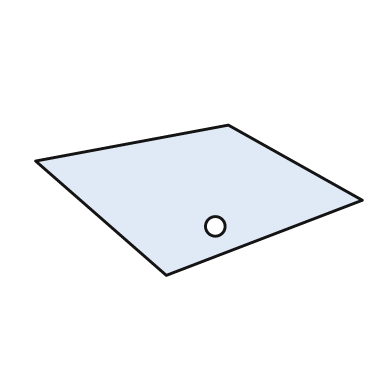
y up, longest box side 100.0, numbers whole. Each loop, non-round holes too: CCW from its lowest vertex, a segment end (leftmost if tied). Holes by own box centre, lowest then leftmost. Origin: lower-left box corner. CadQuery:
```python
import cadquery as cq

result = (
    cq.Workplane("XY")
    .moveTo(40.0, 0.0)
    .lineTo(100.0, 23.0)
    .lineTo(59.0, 46.0)
    .lineTo(0.0, 35.0)
    .close()
    .moveTo(55.0, 15.0)
    .circle(3.0)
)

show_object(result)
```